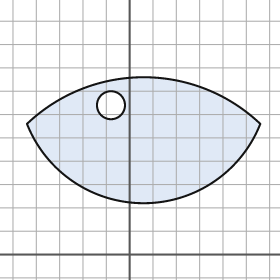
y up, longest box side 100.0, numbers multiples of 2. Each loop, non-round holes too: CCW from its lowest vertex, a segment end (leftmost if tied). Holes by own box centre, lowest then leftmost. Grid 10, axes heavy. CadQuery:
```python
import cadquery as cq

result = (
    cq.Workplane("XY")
    .moveTo(-44.0, 56.0)
    .threePointArc((6.0, 22.0), (56.0, 56.0))
    .threePointArc((6.0, 76.0), (-44.0, 56.0))
    .close()
    .moveTo(-8.0, 64.0)
    .circle(6.0)
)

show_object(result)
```